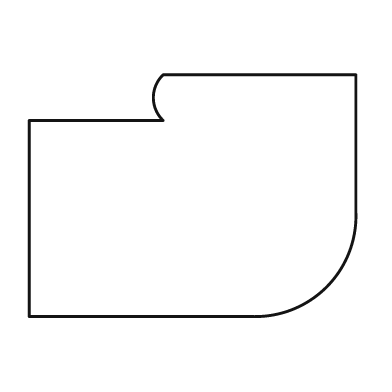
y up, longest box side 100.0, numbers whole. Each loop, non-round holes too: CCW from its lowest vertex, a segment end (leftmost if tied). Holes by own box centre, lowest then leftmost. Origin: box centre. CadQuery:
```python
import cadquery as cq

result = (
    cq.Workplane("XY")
    .moveTo(-50.0, -37.0)
    .lineTo(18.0, -37.0)
    .threePointArc((41.0, -28.0), (50.0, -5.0))
    .lineTo(50.0, 37.0)
    .lineTo(-9.0, 37.0)
    .threePointArc((-12.0, 30.0), (-9.0, 23.0))
    .lineTo(-50.0, 23.0)
    .close()
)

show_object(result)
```